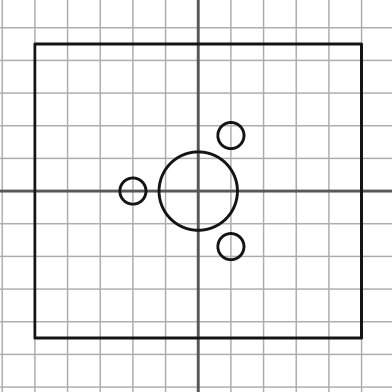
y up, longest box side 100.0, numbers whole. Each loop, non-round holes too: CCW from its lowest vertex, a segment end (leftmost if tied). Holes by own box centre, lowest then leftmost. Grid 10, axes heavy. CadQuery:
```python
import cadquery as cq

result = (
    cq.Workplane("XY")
    .moveTo(-50.0, -45.0)
    .lineTo(50.0, -45.0)
    .lineTo(50.0, 45.0)
    .lineTo(-50.0, 45.0)
    .close()
    .moveTo(10.0, -17.0)
    .circle(4.0)
    .moveTo(-20.0, 0.0)
    .circle(4.0)
    .moveTo(0.0, 0.0)
    .circle(12.0)
    .moveTo(10.0, 17.0)
    .circle(4.0)
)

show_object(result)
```